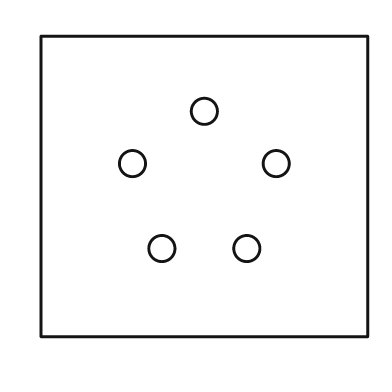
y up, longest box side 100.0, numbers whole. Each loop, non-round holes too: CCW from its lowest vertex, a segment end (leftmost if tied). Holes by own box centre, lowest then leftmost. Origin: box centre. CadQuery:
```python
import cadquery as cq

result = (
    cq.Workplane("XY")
    .moveTo(-50.0, -46.0)
    .lineTo(50.0, -46.0)
    .lineTo(50.0, 46.0)
    .lineTo(-50.0, 46.0)
    .close()
    .moveTo(-13.0, -19.0)
    .circle(4.0)
    .moveTo(13.0, -19.0)
    .circle(4.0)
    .moveTo(-22.0, 7.0)
    .circle(4.0)
    .moveTo(22.0, 7.0)
    .circle(4.0)
    .moveTo(0.0, 23.0)
    .circle(4.0)
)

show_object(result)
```